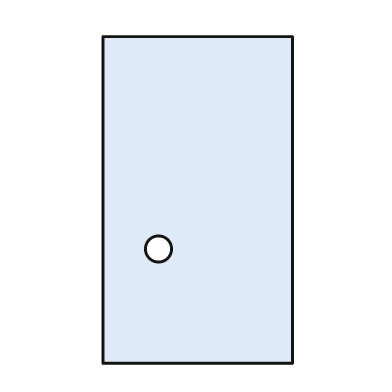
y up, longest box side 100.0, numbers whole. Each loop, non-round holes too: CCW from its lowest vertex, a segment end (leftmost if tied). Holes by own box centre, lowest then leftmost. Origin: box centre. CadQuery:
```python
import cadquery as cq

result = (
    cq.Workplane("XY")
    .moveTo(-29.0, -50.0)
    .lineTo(29.0, -50.0)
    .lineTo(29.0, 50.0)
    .lineTo(-29.0, 50.0)
    .close()
    .moveTo(-12.0, -15.0)
    .circle(4.0)
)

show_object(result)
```